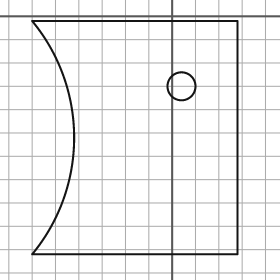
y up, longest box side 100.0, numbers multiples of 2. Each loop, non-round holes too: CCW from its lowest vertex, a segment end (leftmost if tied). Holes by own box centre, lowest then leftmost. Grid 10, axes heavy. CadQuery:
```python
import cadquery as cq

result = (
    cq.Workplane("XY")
    .moveTo(-60.0, -102.0)
    .lineTo(28.0, -102.0)
    .lineTo(28.0, -2.0)
    .lineTo(-60.0, -2.0)
    .threePointArc((-42.0, -52.0), (-60.0, -102.0))
    .close()
    .moveTo(4.0, -30.0)
    .circle(6.0)
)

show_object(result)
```